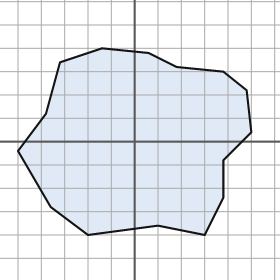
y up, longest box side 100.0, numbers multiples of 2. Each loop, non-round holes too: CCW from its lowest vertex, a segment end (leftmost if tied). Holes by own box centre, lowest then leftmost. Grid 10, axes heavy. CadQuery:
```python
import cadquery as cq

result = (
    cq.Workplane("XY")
    .moveTo(-20.0, -40.0)
    .lineTo(10.0, -36.0)
    .lineTo(30.0, -40.0)
    .lineTo(38.0, -24.0)
    .lineTo(38.0, -8.0)
    .lineTo(50.0, 4.0)
    .lineTo(48.0, 22.0)
    .lineTo(38.0, 30.0)
    .lineTo(18.0, 32.0)
    .lineTo(6.0, 38.0)
    .lineTo(-14.0, 40.0)
    .lineTo(-32.0, 34.0)
    .lineTo(-38.0, 12.0)
    .lineTo(-50.0, -4.0)
    .lineTo(-36.0, -28.0)
    .close()
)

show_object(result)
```